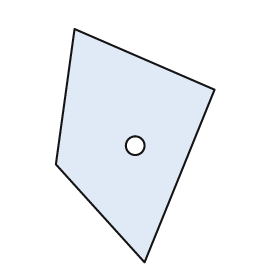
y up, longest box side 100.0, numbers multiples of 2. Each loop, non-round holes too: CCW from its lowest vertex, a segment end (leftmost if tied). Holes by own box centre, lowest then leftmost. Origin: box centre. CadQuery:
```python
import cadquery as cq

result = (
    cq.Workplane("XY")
    .moveTo(4.0, -50.0)
    .lineTo(34.0, 24.0)
    .lineTo(-26.0, 50.0)
    .lineTo(-34.0, -8.0)
    .close()
    .moveTo(0.0, 0.0)
    .circle(4.0)
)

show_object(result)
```